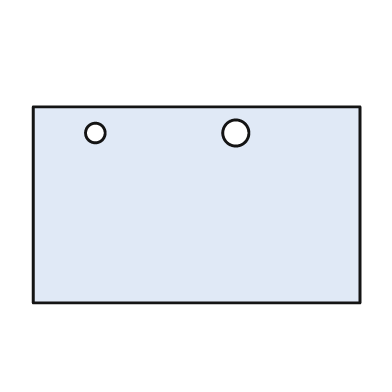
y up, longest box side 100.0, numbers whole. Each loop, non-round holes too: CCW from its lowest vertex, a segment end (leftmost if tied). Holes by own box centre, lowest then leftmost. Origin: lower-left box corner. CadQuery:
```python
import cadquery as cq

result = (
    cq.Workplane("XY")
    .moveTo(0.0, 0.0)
    .lineTo(100.0, 0.0)
    .lineTo(100.0, 60.0)
    .lineTo(0.0, 60.0)
    .close()
    .moveTo(19.0, 52.0)
    .circle(3.0)
    .moveTo(62.0, 52.0)
    .circle(4.0)
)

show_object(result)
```